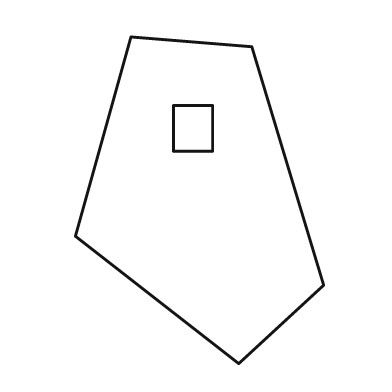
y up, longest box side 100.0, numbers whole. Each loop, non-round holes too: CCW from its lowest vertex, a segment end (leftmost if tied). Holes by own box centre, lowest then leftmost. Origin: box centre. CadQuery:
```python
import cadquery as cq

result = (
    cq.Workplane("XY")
    .moveTo(12.0, -50.0)
    .lineTo(38.0, -26.0)
    .lineTo(16.0, 47.0)
    .lineTo(-21.0, 50.0)
    .lineTo(-38.0, -11.0)
    .close()
    .moveTo(-8.0, 15.0)
    .lineTo(4.0, 15.0)
    .lineTo(4.0, 29.0)
    .lineTo(-8.0, 29.0)
    .close()
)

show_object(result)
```